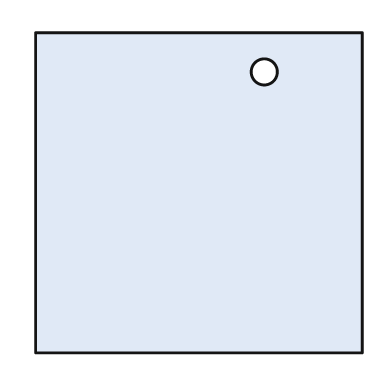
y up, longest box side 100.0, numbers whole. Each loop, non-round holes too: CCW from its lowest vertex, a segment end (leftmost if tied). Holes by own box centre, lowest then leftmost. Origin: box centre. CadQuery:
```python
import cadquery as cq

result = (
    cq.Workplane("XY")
    .moveTo(-50.0, -49.0)
    .lineTo(50.0, -49.0)
    .lineTo(50.0, 49.0)
    .lineTo(-50.0, 49.0)
    .close()
    .moveTo(20.0, 37.0)
    .circle(4.0)
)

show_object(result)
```